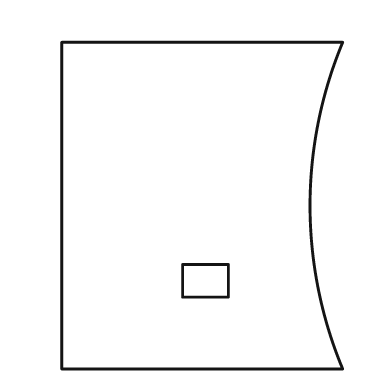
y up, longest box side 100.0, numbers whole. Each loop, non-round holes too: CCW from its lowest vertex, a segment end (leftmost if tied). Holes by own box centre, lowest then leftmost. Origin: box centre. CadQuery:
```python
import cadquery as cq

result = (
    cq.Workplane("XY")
    .moveTo(-43.0, -50.0)
    .lineTo(43.0, -50.0)
    .threePointArc((33.0, 0.0), (43.0, 50.0))
    .lineTo(-43.0, 50.0)
    .close()
    .moveTo(-6.0, -28.0)
    .lineTo(8.0, -28.0)
    .lineTo(8.0, -18.0)
    .lineTo(-6.0, -18.0)
    .close()
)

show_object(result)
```